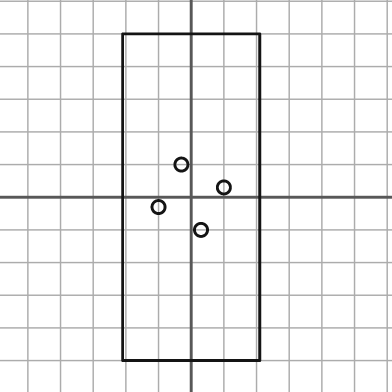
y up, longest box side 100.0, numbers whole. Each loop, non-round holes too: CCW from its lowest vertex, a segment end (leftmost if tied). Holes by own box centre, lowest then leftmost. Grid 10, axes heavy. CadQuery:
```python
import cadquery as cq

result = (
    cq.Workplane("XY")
    .moveTo(-21.0, -50.0)
    .lineTo(21.0, -50.0)
    .lineTo(21.0, 50.0)
    .lineTo(-21.0, 50.0)
    .close()
    .moveTo(3.0, -10.0)
    .circle(2.0)
    .moveTo(-10.0, -3.0)
    .circle(2.0)
    .moveTo(10.0, 3.0)
    .circle(2.0)
    .moveTo(-3.0, 10.0)
    .circle(2.0)
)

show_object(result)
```